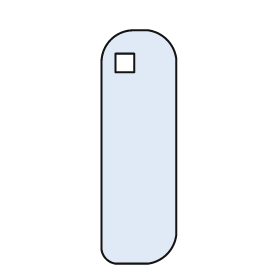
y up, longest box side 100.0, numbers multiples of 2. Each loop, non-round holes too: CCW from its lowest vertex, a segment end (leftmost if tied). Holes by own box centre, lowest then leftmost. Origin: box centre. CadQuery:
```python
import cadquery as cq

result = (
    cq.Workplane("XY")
    .moveTo(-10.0, -50.0)
    .lineTo(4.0, -50.0)
    .threePointArc((12.0, -46.0), (16.0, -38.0))
    .lineTo(16.0, 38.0)
    .threePointArc((12.0, 46.0), (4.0, 50.0))
    .lineTo(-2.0, 50.0)
    .threePointArc((-12.0, 46.0), (-16.0, 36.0))
    .lineTo(-16.0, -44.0)
    .threePointArc((-14.0, -48.0), (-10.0, -50.0))
    .close()
    .moveTo(-10.0, 32.0)
    .lineTo(-2.0, 32.0)
    .lineTo(-2.0, 40.0)
    .lineTo(-10.0, 40.0)
    .close()
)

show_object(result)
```